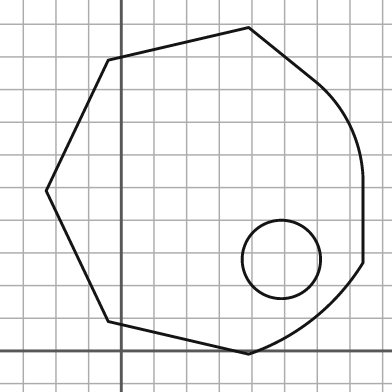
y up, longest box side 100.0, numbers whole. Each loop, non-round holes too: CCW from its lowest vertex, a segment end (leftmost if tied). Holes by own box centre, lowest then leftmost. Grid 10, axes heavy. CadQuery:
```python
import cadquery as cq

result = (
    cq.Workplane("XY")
    .moveTo(39.0, -1.0)
    .threePointArc((59.0, 10.0), (74.0, 27.0))
    .lineTo(74.0, 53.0)
    .threePointArc((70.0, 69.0), (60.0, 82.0))
    .lineTo(39.0, 99.0)
    .lineTo(-4.0, 89.0)
    .lineTo(-23.0, 49.0)
    .lineTo(-4.0, 9.0)
    .close()
    .moveTo(49.0, 28.0)
    .circle(12.0)
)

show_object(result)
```